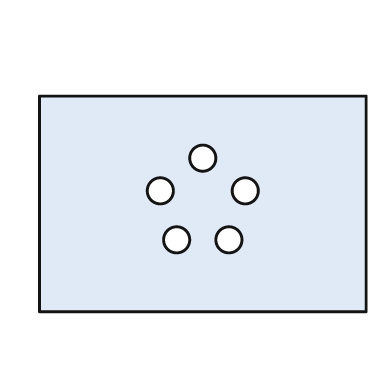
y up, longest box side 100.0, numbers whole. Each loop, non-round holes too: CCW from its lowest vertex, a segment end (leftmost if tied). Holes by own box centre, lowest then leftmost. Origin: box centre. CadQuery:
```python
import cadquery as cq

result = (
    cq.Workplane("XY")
    .moveTo(-50.0, -33.0)
    .lineTo(50.0, -33.0)
    .lineTo(50.0, 33.0)
    .lineTo(-50.0, 33.0)
    .close()
    .moveTo(-8.0, -11.0)
    .circle(4.0)
    .moveTo(8.0, -11.0)
    .circle(4.0)
    .moveTo(-13.0, 4.0)
    .circle(4.0)
    .moveTo(13.0, 4.0)
    .circle(4.0)
    .moveTo(0.0, 14.0)
    .circle(4.0)
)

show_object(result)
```